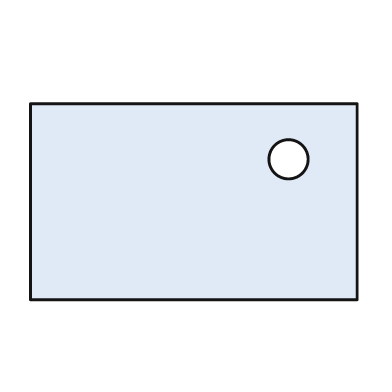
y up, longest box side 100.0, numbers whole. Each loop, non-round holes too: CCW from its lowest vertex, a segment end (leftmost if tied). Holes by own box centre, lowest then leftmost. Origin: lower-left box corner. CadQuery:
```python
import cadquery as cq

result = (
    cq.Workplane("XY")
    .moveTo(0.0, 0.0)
    .lineTo(100.0, 0.0)
    .lineTo(100.0, 60.0)
    .lineTo(0.0, 60.0)
    .close()
    .moveTo(79.0, 43.0)
    .circle(6.0)
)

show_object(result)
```